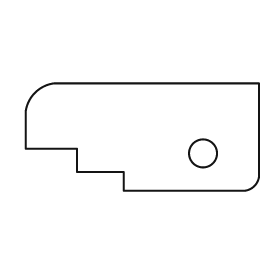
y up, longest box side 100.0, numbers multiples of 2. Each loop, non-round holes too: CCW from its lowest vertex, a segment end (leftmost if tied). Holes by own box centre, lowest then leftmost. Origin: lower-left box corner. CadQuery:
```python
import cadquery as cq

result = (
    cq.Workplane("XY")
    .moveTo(42.0, 0.0)
    .lineTo(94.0, 0.0)
    .threePointArc((98.0, 2.0), (100.0, 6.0))
    .lineTo(100.0, 46.0)
    .lineTo(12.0, 46.0)
    .threePointArc((4.0, 42.0), (0.0, 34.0))
    .lineTo(0.0, 18.0)
    .lineTo(22.0, 18.0)
    .lineTo(22.0, 8.0)
    .lineTo(42.0, 8.0)
    .close()
    .moveTo(76.0, 16.0)
    .circle(6.0)
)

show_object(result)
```